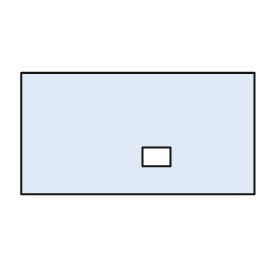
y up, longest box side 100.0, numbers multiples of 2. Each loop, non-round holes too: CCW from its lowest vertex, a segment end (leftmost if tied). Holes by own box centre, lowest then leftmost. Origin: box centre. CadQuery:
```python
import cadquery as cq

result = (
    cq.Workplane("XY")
    .moveTo(-50.0, -26.0)
    .lineTo(50.0, -26.0)
    .lineTo(50.0, 26.0)
    .lineTo(-50.0, 26.0)
    .close()
    .moveTo(2.0, -14.0)
    .lineTo(14.0, -14.0)
    .lineTo(14.0, -6.0)
    .lineTo(2.0, -6.0)
    .close()
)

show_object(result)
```